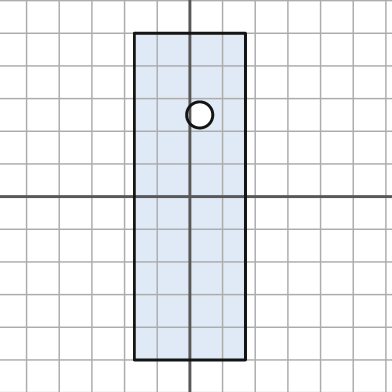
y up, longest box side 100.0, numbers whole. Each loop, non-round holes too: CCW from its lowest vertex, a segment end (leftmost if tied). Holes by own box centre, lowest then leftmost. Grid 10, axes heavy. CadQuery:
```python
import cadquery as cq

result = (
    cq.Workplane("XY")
    .moveTo(-17.0, -50.0)
    .lineTo(17.0, -50.0)
    .lineTo(17.0, 50.0)
    .lineTo(-17.0, 50.0)
    .close()
    .moveTo(3.0, 25.0)
    .circle(4.0)
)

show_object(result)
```